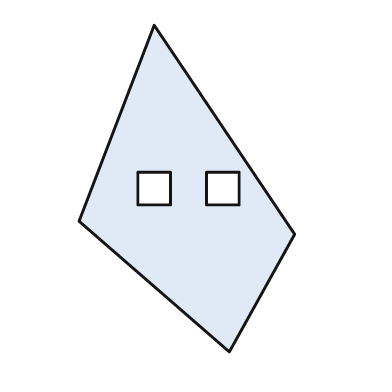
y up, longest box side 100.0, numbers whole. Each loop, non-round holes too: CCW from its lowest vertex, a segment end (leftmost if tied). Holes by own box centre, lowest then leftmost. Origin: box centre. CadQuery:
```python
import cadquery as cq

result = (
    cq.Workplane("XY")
    .moveTo(13.0, -50.0)
    .lineTo(33.0, -14.0)
    .lineTo(-10.0, 50.0)
    .lineTo(-33.0, -10.0)
    .close()
    .moveTo(-15.0, -5.0)
    .lineTo(-5.0, -5.0)
    .lineTo(-5.0, 5.0)
    .lineTo(-15.0, 5.0)
    .close()
    .moveTo(6.0, -5.0)
    .lineTo(16.0, -5.0)
    .lineTo(16.0, 5.0)
    .lineTo(6.0, 5.0)
    .close()
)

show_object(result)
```